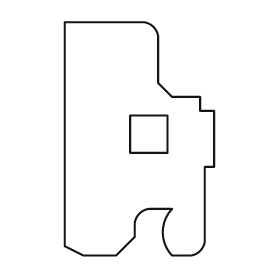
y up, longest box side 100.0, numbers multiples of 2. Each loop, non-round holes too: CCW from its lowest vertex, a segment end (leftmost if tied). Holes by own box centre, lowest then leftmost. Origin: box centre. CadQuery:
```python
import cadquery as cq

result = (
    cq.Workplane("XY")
    .moveTo(-24.0, -50.0)
    .lineTo(-10.0, -50.0)
    .lineTo(-2.0, -42.0)
    .lineTo(-2.0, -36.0)
    .threePointArc((0.0, -32.0), (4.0, -30.0))
    .lineTo(14.0, -30.0)
    .threePointArc((10.0, -40.0), (14.0, -50.0))
    .lineTo(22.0, -50.0)
    .threePointArc((26.0, -48.0), (28.0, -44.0))
    .lineTo(28.0, -12.0)
    .lineTo(32.0, -12.0)
    .lineTo(32.0, 12.0)
    .lineTo(26.0, 12.0)
    .lineTo(26.0, 18.0)
    .lineTo(14.0, 18.0)
    .lineTo(8.0, 24.0)
    .lineTo(8.0, 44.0)
    .threePointArc((6.0, 48.0), (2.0, 50.0))
    .lineTo(-32.0, 50.0)
    .lineTo(-32.0, -46.0)
    .close()
    .moveTo(-4.0, -6.0)
    .lineTo(12.0, -6.0)
    .lineTo(12.0, 10.0)
    .lineTo(-4.0, 10.0)
    .close()
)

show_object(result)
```